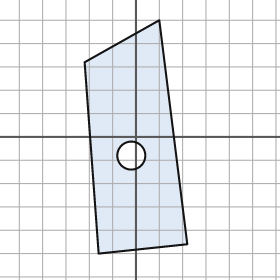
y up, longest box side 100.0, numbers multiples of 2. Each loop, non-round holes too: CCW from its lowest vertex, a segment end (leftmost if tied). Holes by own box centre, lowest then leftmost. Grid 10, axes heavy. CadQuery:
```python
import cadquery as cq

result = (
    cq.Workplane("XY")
    .moveTo(-16.0, -50.0)
    .lineTo(22.0, -46.0)
    .lineTo(10.0, 50.0)
    .lineTo(-22.0, 32.0)
    .close()
    .moveTo(-2.0, -8.0)
    .circle(6.0)
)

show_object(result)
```